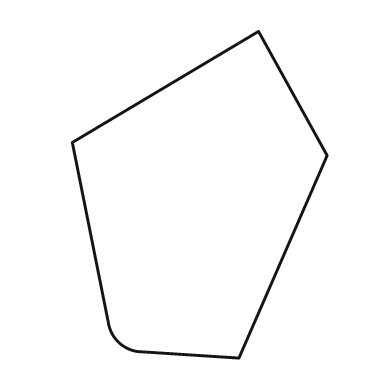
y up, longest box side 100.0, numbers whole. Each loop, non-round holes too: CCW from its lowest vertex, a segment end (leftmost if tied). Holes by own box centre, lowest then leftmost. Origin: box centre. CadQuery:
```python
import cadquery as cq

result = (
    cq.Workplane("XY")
    .moveTo(12.0, -50.0)
    .lineTo(39.0, 12.0)
    .lineTo(18.0, 50.0)
    .lineTo(-39.0, 16.0)
    .lineTo(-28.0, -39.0)
    .threePointArc((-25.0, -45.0), (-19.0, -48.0))
    .close()
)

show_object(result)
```